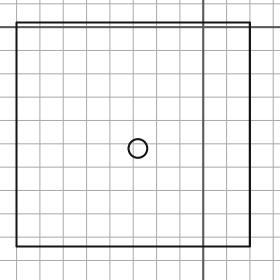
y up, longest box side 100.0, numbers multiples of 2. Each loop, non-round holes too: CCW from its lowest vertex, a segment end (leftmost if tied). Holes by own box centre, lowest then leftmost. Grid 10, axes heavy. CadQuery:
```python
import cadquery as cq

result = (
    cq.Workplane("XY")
    .moveTo(-80.0, -94.0)
    .lineTo(20.0, -94.0)
    .lineTo(20.0, 2.0)
    .lineTo(-80.0, 2.0)
    .close()
    .moveTo(-28.0, -52.0)
    .circle(4.0)
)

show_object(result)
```